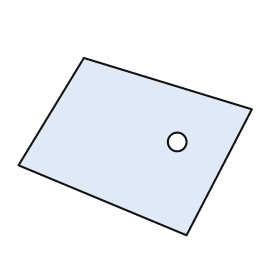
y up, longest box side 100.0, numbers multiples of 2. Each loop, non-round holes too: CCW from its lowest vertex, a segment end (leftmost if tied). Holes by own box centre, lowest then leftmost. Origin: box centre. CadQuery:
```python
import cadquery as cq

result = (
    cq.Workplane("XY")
    .moveTo(22.0, -38.0)
    .lineTo(50.0, 16.0)
    .lineTo(-22.0, 38.0)
    .lineTo(-50.0, -8.0)
    .close()
    .moveTo(18.0, 2.0)
    .circle(4.0)
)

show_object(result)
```